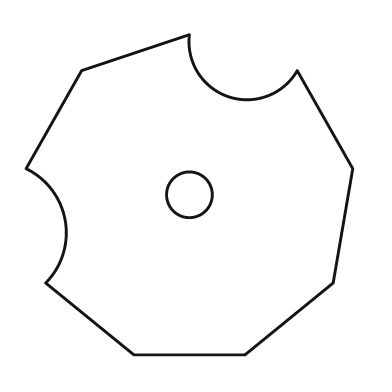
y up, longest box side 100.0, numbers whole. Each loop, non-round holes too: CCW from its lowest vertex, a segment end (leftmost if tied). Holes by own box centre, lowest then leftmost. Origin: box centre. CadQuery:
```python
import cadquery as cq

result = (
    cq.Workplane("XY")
    .moveTo(-17.0, -49.0)
    .lineTo(17.0, -49.0)
    .lineTo(44.0, -27.0)
    .lineTo(50.0, 8.0)
    .lineTo(33.0, 38.0)
    .threePointArc((12.0, 30.0), (0.0, 49.0))
    .lineTo(-33.0, 38.0)
    .lineTo(-50.0, 8.0)
    .threePointArc((-38.0, -8.0), (-44.0, -27.0))
    .close()
    .moveTo(0.0, 0.0)
    .circle(7.0)
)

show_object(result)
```